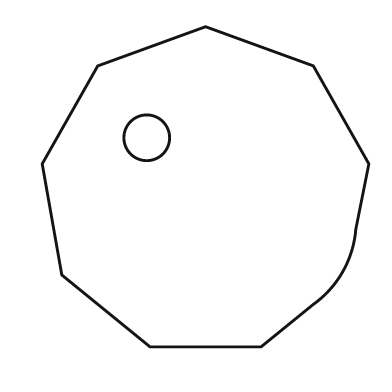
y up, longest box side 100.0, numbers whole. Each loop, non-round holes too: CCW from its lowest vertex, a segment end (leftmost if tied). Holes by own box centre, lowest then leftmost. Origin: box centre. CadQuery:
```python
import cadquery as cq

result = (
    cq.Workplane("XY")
    .moveTo(-17.0, -49.0)
    .lineTo(17.0, -49.0)
    .lineTo(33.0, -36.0)
    .threePointArc((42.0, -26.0), (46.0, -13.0))
    .lineTo(50.0, 7.0)
    .lineTo(33.0, 37.0)
    .lineTo(0.0, 49.0)
    .lineTo(-33.0, 37.0)
    .lineTo(-50.0, 7.0)
    .lineTo(-44.0, -27.0)
    .close()
    .moveTo(-18.0, 15.0)
    .circle(7.0)
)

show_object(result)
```